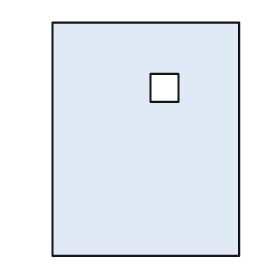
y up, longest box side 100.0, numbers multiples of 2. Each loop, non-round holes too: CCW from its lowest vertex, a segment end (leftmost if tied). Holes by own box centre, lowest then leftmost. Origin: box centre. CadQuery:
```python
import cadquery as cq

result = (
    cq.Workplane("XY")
    .moveTo(-40.0, -50.0)
    .lineTo(40.0, -50.0)
    .lineTo(40.0, 50.0)
    .lineTo(-40.0, 50.0)
    .close()
    .moveTo(2.0, 16.0)
    .lineTo(14.0, 16.0)
    .lineTo(14.0, 28.0)
    .lineTo(2.0, 28.0)
    .close()
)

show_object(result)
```